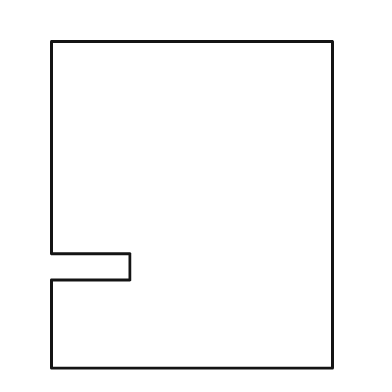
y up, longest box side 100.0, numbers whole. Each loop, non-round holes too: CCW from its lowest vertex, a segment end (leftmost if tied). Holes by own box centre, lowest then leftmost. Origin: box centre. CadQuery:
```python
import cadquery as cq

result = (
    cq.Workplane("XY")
    .moveTo(-43.0, -50.0)
    .lineTo(43.0, -50.0)
    .lineTo(43.0, 50.0)
    .lineTo(-43.0, 50.0)
    .lineTo(-43.0, -15.0)
    .lineTo(-19.0, -15.0)
    .lineTo(-19.0, -23.0)
    .lineTo(-43.0, -23.0)
    .close()
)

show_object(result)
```